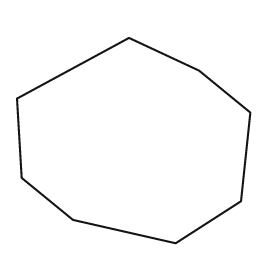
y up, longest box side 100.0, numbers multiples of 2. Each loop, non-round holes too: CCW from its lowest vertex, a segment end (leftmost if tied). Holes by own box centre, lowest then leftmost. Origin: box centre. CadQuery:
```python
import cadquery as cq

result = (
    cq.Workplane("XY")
    .moveTo(18.0, -44.0)
    .lineTo(46.0, -26.0)
    .lineTo(50.0, 12.0)
    .lineTo(28.0, 30.0)
    .lineTo(-2.0, 44.0)
    .lineTo(-50.0, 18.0)
    .lineTo(-48.0, -16.0)
    .lineTo(-26.0, -34.0)
    .close()
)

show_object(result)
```